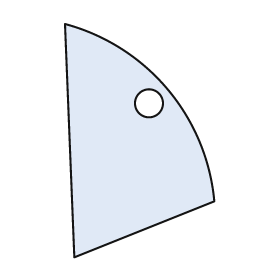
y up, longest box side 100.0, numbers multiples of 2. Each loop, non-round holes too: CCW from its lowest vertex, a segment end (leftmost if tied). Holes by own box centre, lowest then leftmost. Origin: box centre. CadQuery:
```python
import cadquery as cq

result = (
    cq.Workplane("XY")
    .moveTo(-28.0, -50.0)
    .lineTo(32.0, -26.0)
    .threePointArc((12.0, 22.0), (-32.0, 50.0))
    .close()
    .moveTo(4.0, 16.0)
    .circle(6.0)
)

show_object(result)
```